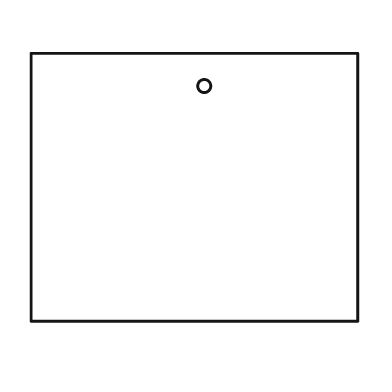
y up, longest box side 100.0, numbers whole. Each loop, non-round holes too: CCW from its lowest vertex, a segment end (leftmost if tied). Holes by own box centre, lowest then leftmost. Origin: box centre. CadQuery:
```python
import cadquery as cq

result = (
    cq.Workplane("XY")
    .moveTo(-50.0, -41.0)
    .lineTo(50.0, -41.0)
    .lineTo(50.0, 41.0)
    .lineTo(-50.0, 41.0)
    .close()
    .moveTo(3.0, 31.0)
    .circle(2.0)
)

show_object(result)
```